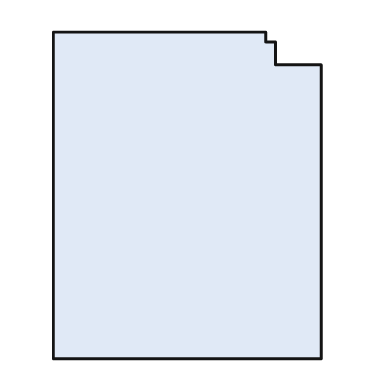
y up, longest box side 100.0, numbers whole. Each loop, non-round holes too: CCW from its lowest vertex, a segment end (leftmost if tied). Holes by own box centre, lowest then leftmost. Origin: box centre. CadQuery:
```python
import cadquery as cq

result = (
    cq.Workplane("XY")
    .moveTo(-41.0, -50.0)
    .lineTo(41.0, -50.0)
    .lineTo(41.0, 40.0)
    .lineTo(27.0, 40.0)
    .lineTo(27.0, 47.0)
    .lineTo(24.0, 47.0)
    .lineTo(24.0, 50.0)
    .lineTo(-41.0, 50.0)
    .close()
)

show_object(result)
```